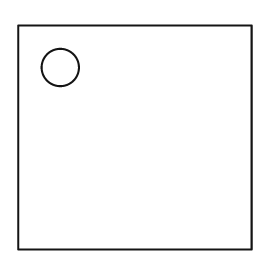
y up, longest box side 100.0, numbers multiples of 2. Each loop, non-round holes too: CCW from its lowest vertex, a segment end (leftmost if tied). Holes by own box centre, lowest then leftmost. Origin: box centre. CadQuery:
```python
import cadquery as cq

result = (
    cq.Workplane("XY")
    .moveTo(-50.0, -48.0)
    .lineTo(50.0, -48.0)
    .lineTo(50.0, 48.0)
    .lineTo(-50.0, 48.0)
    .close()
    .moveTo(-32.0, 30.0)
    .circle(8.0)
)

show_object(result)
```